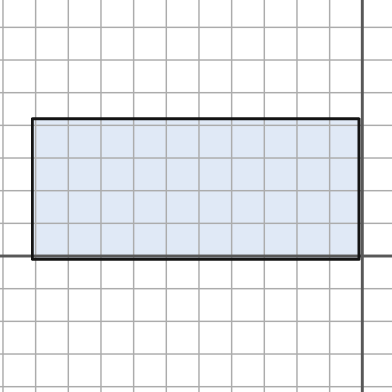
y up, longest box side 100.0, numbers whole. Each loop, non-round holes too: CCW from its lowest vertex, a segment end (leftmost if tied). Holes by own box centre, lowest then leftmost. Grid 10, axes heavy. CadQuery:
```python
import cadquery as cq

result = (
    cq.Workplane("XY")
    .moveTo(-101.0, -1.0)
    .lineTo(-1.0, -1.0)
    .lineTo(-1.0, 42.0)
    .lineTo(-101.0, 42.0)
    .close()
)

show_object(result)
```